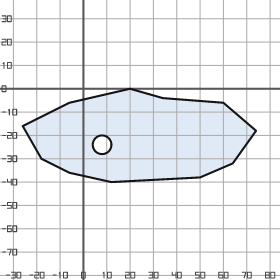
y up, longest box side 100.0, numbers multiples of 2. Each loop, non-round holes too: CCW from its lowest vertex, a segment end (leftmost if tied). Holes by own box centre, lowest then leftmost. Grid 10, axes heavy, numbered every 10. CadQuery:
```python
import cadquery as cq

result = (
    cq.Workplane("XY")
    .moveTo(12.0, -40.0)
    .lineTo(50.0, -38.0)
    .lineTo(64.0, -32.0)
    .lineTo(74.0, -18.0)
    .lineTo(60.0, -6.0)
    .lineTo(34.0, -4.0)
    .lineTo(20.0, 0.0)
    .lineTo(-6.0, -6.0)
    .lineTo(-26.0, -16.0)
    .lineTo(-18.0, -30.0)
    .lineTo(-6.0, -36.0)
    .close()
    .moveTo(8.0, -24.0)
    .circle(4.0)
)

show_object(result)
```